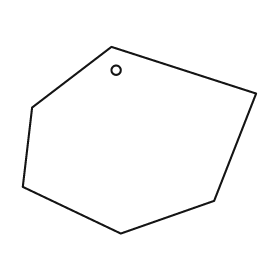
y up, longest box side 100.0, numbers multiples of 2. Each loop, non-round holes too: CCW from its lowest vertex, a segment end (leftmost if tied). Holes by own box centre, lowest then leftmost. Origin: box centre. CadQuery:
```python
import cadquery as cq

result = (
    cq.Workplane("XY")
    .moveTo(-8.0, -40.0)
    .lineTo(32.0, -26.0)
    .lineTo(50.0, 20.0)
    .lineTo(-12.0, 40.0)
    .lineTo(-46.0, 14.0)
    .lineTo(-50.0, -20.0)
    .close()
    .moveTo(-10.0, 30.0)
    .circle(2.0)
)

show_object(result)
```